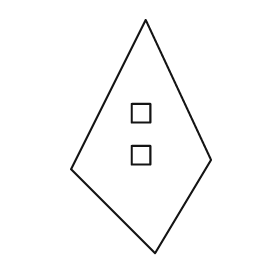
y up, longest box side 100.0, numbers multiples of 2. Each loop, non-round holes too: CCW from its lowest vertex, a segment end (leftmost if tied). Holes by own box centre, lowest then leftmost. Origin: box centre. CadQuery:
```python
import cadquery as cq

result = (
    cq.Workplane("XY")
    .moveTo(6.0, -50.0)
    .lineTo(30.0, -10.0)
    .lineTo(2.0, 50.0)
    .lineTo(-30.0, -14.0)
    .close()
    .moveTo(-4.0, -12.0)
    .lineTo(4.0, -12.0)
    .lineTo(4.0, -4.0)
    .lineTo(-4.0, -4.0)
    .close()
    .moveTo(-4.0, 6.0)
    .lineTo(4.0, 6.0)
    .lineTo(4.0, 14.0)
    .lineTo(-4.0, 14.0)
    .close()
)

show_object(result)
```